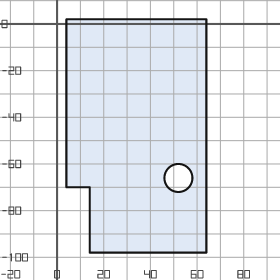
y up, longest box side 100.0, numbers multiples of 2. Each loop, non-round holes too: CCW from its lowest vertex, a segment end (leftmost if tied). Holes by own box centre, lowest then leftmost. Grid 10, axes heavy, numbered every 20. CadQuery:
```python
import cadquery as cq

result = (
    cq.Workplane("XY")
    .moveTo(14.0, -98.0)
    .lineTo(64.0, -98.0)
    .lineTo(64.0, 2.0)
    .lineTo(4.0, 2.0)
    .lineTo(4.0, -70.0)
    .lineTo(14.0, -70.0)
    .close()
    .moveTo(52.0, -66.0)
    .circle(6.0)
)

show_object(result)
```